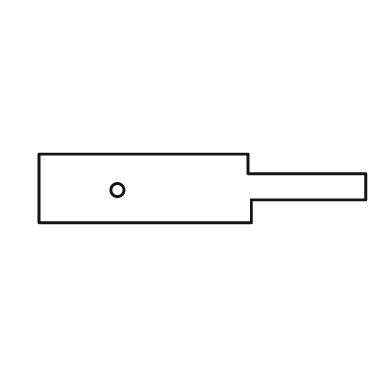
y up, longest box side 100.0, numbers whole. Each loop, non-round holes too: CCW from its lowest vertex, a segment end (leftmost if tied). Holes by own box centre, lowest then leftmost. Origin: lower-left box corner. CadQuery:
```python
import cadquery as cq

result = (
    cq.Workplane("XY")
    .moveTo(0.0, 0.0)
    .lineTo(65.0, 0.0)
    .lineTo(65.0, 7.0)
    .lineTo(100.0, 7.0)
    .lineTo(100.0, 15.0)
    .lineTo(64.0, 15.0)
    .lineTo(64.0, 21.0)
    .lineTo(0.0, 21.0)
    .close()
    .moveTo(24.0, 10.0)
    .circle(2.0)
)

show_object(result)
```